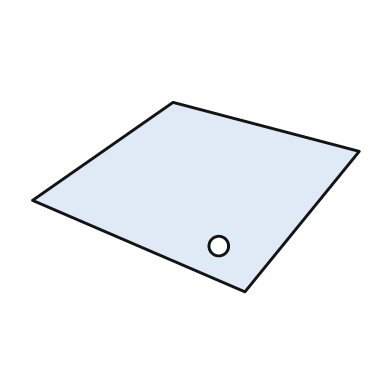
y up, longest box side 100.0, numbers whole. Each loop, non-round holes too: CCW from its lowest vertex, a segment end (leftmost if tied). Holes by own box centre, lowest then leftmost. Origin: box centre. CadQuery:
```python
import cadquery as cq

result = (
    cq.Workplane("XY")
    .moveTo(15.0, -29.0)
    .lineTo(50.0, 14.0)
    .lineTo(-7.0, 29.0)
    .lineTo(-50.0, -1.0)
    .close()
    .moveTo(7.0, -15.0)
    .circle(3.0)
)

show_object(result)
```